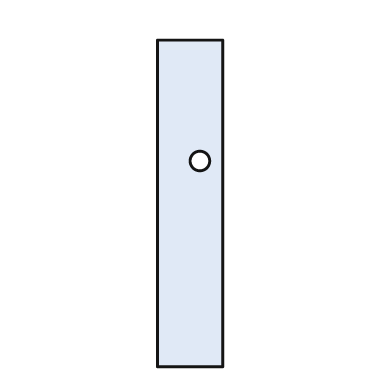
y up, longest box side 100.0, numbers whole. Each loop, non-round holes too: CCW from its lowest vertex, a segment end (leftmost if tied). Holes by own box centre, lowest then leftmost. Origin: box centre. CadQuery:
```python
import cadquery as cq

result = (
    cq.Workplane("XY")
    .moveTo(-10.0, -50.0)
    .lineTo(10.0, -50.0)
    .lineTo(10.0, 50.0)
    .lineTo(-10.0, 50.0)
    .close()
    .moveTo(3.0, 13.0)
    .circle(3.0)
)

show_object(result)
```